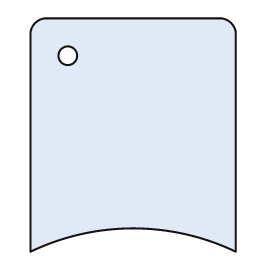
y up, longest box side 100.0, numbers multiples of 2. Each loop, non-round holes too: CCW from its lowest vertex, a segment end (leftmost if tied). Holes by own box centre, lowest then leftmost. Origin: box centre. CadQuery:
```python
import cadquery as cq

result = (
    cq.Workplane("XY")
    .moveTo(-44.0, -50.0)
    .threePointArc((0.0, -40.0), (44.0, -50.0))
    .lineTo(44.0, 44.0)
    .threePointArc((42.0, 48.0), (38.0, 50.0))
    .lineTo(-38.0, 50.0)
    .threePointArc((-42.0, 48.0), (-44.0, 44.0))
    .close()
    .moveTo(-28.0, 34.0)
    .circle(4.0)
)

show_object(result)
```